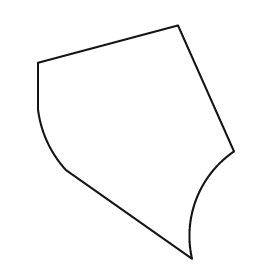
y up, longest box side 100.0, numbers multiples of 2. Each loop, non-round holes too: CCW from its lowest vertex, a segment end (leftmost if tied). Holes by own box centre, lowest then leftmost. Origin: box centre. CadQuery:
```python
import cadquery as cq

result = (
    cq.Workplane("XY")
    .moveTo(24.0, -50.0)
    .threePointArc((26.0, -24.0), (42.0, -4.0))
    .lineTo(18.0, 50.0)
    .lineTo(-42.0, 34.0)
    .lineTo(-42.0, 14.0)
    .threePointArc((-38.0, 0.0), (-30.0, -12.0))
    .close()
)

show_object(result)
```